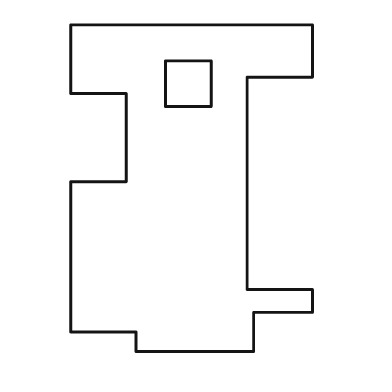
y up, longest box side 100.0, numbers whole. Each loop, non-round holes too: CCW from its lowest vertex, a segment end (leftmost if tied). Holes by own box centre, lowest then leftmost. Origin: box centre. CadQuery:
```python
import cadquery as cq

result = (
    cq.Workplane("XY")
    .moveTo(-17.0, -50.0)
    .lineTo(19.0, -50.0)
    .lineTo(19.0, -38.0)
    .lineTo(37.0, -38.0)
    .lineTo(37.0, -31.0)
    .lineTo(17.0, -31.0)
    .lineTo(17.0, 34.0)
    .lineTo(37.0, 34.0)
    .lineTo(37.0, 50.0)
    .lineTo(-37.0, 50.0)
    .lineTo(-37.0, 29.0)
    .lineTo(-20.0, 29.0)
    .lineTo(-20.0, 2.0)
    .lineTo(-37.0, 2.0)
    .lineTo(-37.0, -44.0)
    .lineTo(-17.0, -44.0)
    .close()
    .moveTo(-8.0, 25.0)
    .lineTo(6.0, 25.0)
    .lineTo(6.0, 39.0)
    .lineTo(-8.0, 39.0)
    .close()
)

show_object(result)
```